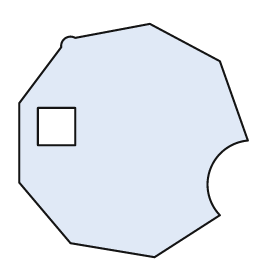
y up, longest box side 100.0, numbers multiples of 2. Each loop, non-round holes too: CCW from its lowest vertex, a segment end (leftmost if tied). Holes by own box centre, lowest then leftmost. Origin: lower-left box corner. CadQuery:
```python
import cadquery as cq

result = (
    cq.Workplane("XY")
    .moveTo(58.0, 0.0)
    .lineTo(86.0, 18.0)
    .threePointArc((82.0, 38.0), (98.0, 50.0))
    .lineTo(86.0, 84.0)
    .lineTo(56.0, 100.0)
    .lineTo(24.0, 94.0)
    .threePointArc((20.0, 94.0), (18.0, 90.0))
    .lineTo(0.0, 66.0)
    .lineTo(0.0, 32.0)
    .lineTo(22.0, 6.0)
    .close()
    .moveTo(8.0, 48.0)
    .lineTo(24.0, 48.0)
    .lineTo(24.0, 64.0)
    .lineTo(8.0, 64.0)
    .close()
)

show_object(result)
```